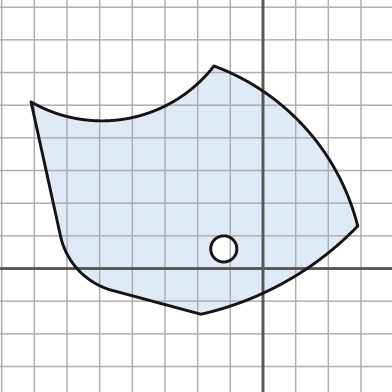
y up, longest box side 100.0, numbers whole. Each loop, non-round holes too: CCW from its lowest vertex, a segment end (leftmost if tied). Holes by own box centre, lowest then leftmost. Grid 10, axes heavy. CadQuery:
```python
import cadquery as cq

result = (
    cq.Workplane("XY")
    .moveTo(-19.0, -14.0)
    .threePointArc((7.0, -4.0), (29.0, 13.0))
    .threePointArc((13.0, 43.0), (-15.0, 62.0))
    .threePointArc((-41.0, 46.0), (-71.0, 51.0))
    .lineTo(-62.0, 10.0)
    .threePointArc((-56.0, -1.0), (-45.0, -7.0))
    .close()
    .moveTo(-12.0, 6.0)
    .circle(4.0)
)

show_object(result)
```